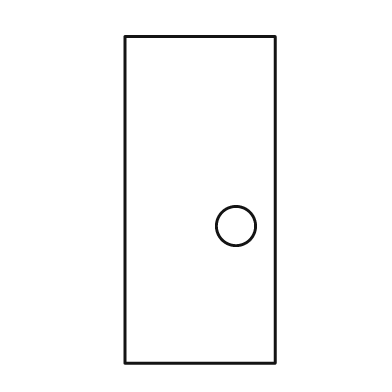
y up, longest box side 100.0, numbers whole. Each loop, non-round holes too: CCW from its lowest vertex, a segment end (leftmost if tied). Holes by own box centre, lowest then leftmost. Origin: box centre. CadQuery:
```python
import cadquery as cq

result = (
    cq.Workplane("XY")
    .moveTo(-23.0, -50.0)
    .lineTo(23.0, -50.0)
    .lineTo(23.0, 50.0)
    .lineTo(-23.0, 50.0)
    .close()
    .moveTo(11.0, -8.0)
    .circle(6.0)
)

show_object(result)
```